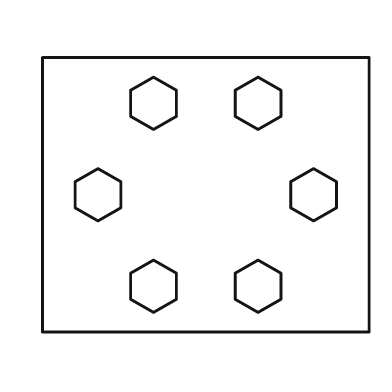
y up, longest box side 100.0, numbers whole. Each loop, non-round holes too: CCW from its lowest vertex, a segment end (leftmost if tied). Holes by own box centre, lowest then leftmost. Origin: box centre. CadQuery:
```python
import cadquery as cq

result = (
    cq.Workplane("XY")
    .moveTo(-50.0, -42.0)
    .lineTo(50.0, -42.0)
    .lineTo(50.0, 42.0)
    .lineTo(-50.0, 42.0)
    .close()
    .moveTo(-16.0, -36.0)
    .lineTo(-9.0, -32.0)
    .lineTo(-9.0, -24.0)
    .lineTo(-16.0, -20.0)
    .lineTo(-23.0, -24.0)
    .lineTo(-23.0, -32.0)
    .close()
    .moveTo(16.0, -36.0)
    .lineTo(23.0, -32.0)
    .lineTo(23.0, -24.0)
    .lineTo(16.0, -20.0)
    .lineTo(9.0, -24.0)
    .lineTo(9.0, -32.0)
    .close()
    .moveTo(-33.0, -8.0)
    .lineTo(-26.0, -4.0)
    .lineTo(-26.0, 4.0)
    .lineTo(-33.0, 8.0)
    .lineTo(-40.0, 4.0)
    .lineTo(-40.0, -4.0)
    .close()
    .moveTo(33.0, -8.0)
    .lineTo(40.0, -4.0)
    .lineTo(40.0, 4.0)
    .lineTo(33.0, 8.0)
    .lineTo(26.0, 4.0)
    .lineTo(26.0, -4.0)
    .close()
    .moveTo(-16.0, 20.0)
    .lineTo(-9.0, 24.0)
    .lineTo(-9.0, 32.0)
    .lineTo(-16.0, 36.0)
    .lineTo(-23.0, 32.0)
    .lineTo(-23.0, 24.0)
    .close()
    .moveTo(16.0, 20.0)
    .lineTo(23.0, 24.0)
    .lineTo(23.0, 32.0)
    .lineTo(16.0, 36.0)
    .lineTo(9.0, 32.0)
    .lineTo(9.0, 24.0)
    .close()
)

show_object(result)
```